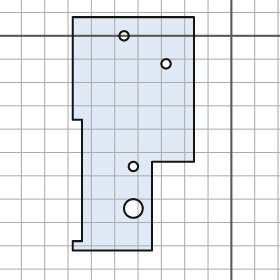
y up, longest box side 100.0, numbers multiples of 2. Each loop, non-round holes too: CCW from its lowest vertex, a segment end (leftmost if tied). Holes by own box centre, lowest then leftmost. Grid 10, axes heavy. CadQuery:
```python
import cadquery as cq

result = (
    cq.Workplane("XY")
    .moveTo(-68.0, -92.0)
    .lineTo(-34.0, -92.0)
    .lineTo(-34.0, -54.0)
    .lineTo(-16.0, -54.0)
    .lineTo(-16.0, 8.0)
    .lineTo(-68.0, 8.0)
    .lineTo(-68.0, -36.0)
    .lineTo(-64.0, -36.0)
    .lineTo(-64.0, -88.0)
    .lineTo(-68.0, -88.0)
    .close()
    .moveTo(-42.0, -74.0)
    .circle(4.0)
    .moveTo(-42.0, -56.0)
    .circle(2.0)
    .moveTo(-28.0, -12.0)
    .circle(2.0)
    .moveTo(-46.0, 0.0)
    .circle(2.0)
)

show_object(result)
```